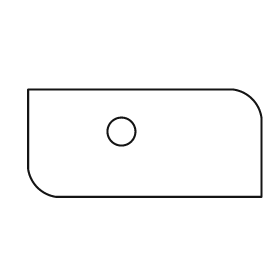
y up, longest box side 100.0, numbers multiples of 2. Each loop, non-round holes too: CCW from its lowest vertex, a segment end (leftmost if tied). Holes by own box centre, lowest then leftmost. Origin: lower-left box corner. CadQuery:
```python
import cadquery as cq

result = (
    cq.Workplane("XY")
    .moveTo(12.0, 0.0)
    .lineTo(100.0, 0.0)
    .lineTo(100.0, 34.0)
    .threePointArc((96.0, 42.0), (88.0, 46.0))
    .lineTo(0.0, 46.0)
    .lineTo(0.0, 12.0)
    .threePointArc((4.0, 4.0), (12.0, 0.0))
    .close()
    .moveTo(40.0, 28.0)
    .circle(6.0)
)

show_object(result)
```